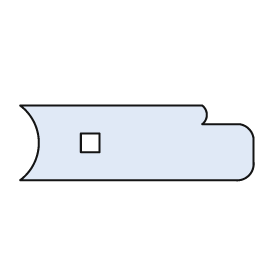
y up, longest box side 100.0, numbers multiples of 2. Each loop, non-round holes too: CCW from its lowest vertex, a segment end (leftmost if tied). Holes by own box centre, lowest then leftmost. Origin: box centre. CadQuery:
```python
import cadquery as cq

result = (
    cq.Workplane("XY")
    .moveTo(-50.0, -16.0)
    .lineTo(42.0, -16.0)
    .threePointArc((48.0, -14.0), (50.0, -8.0))
    .lineTo(50.0, 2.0)
    .threePointArc((48.0, 6.0), (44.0, 8.0))
    .lineTo(28.0, 8.0)
    .threePointArc((30.0, 12.0), (28.0, 16.0))
    .lineTo(-50.0, 16.0)
    .threePointArc((-42.0, 0.0), (-50.0, -16.0))
    .close()
    .moveTo(-24.0, -4.0)
    .lineTo(-16.0, -4.0)
    .lineTo(-16.0, 4.0)
    .lineTo(-24.0, 4.0)
    .close()
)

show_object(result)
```